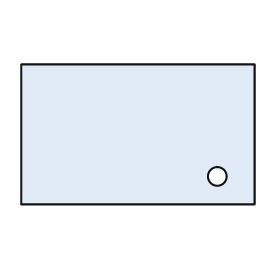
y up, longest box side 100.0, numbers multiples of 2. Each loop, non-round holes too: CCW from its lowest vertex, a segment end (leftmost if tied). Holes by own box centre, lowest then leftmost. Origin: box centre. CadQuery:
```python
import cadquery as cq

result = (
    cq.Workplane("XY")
    .moveTo(-50.0, -30.0)
    .lineTo(50.0, -30.0)
    .lineTo(50.0, 30.0)
    .lineTo(-50.0, 30.0)
    .close()
    .moveTo(34.0, -18.0)
    .circle(4.0)
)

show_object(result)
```